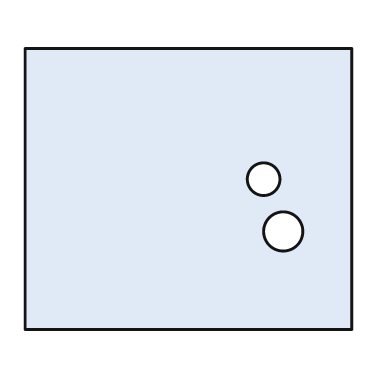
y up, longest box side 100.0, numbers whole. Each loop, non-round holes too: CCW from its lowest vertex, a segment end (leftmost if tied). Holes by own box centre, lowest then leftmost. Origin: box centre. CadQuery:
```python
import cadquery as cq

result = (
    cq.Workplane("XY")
    .moveTo(-50.0, -43.0)
    .lineTo(50.0, -43.0)
    .lineTo(50.0, 43.0)
    .lineTo(-50.0, 43.0)
    .close()
    .moveTo(29.0, -13.0)
    .circle(6.0)
    .moveTo(23.0, 3.0)
    .circle(5.0)
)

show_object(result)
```